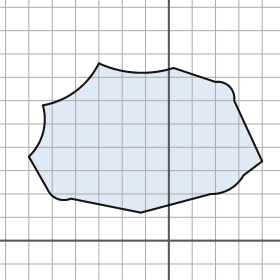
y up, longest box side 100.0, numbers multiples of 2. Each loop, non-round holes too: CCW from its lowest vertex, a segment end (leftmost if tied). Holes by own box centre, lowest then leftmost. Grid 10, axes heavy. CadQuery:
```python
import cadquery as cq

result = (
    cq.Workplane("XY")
    .moveTo(-12.0, 12.0)
    .lineTo(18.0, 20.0)
    .threePointArc((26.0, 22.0), (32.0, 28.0))
    .lineTo(40.0, 34.0)
    .lineTo(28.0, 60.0)
    .threePointArc((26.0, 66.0), (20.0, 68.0))
    .lineTo(2.0, 74.0)
    .threePointArc((-14.0, 72.0), (-30.0, 76.0))
    .threePointArc((-40.0, 64.0), (-54.0, 58.0))
    .threePointArc((-54.0, 46.0), (-60.0, 36.0))
    .lineTo(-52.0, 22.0)
    .threePointArc((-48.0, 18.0), (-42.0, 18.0))
    .close()
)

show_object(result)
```